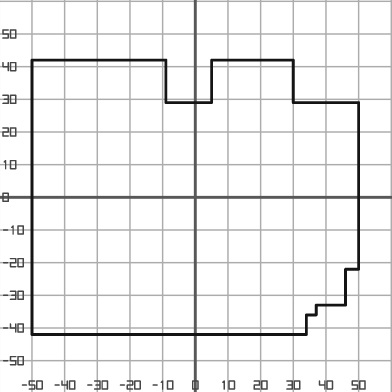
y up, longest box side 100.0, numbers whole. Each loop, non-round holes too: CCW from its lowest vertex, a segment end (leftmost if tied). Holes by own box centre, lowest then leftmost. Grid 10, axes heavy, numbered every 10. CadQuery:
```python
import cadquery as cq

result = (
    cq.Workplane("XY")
    .moveTo(-50.0, -42.0)
    .lineTo(34.0, -42.0)
    .lineTo(34.0, -36.0)
    .lineTo(37.0, -36.0)
    .lineTo(37.0, -33.0)
    .lineTo(46.0, -33.0)
    .lineTo(46.0, -22.0)
    .lineTo(50.0, -22.0)
    .lineTo(50.0, 29.0)
    .lineTo(30.0, 29.0)
    .lineTo(30.0, 42.0)
    .lineTo(5.0, 42.0)
    .lineTo(5.0, 29.0)
    .lineTo(-9.0, 29.0)
    .lineTo(-9.0, 42.0)
    .lineTo(-50.0, 42.0)
    .close()
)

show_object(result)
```